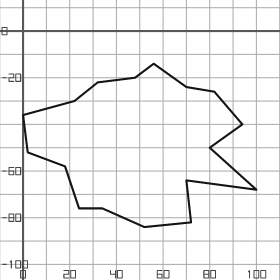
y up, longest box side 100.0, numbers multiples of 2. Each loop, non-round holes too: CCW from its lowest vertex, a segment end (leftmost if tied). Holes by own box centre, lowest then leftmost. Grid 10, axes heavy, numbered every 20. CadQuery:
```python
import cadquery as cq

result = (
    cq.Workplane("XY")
    .moveTo(52.0, -84.0)
    .lineTo(72.0, -82.0)
    .lineTo(70.0, -64.0)
    .lineTo(100.0, -68.0)
    .lineTo(80.0, -50.0)
    .lineTo(94.0, -40.0)
    .lineTo(82.0, -26.0)
    .lineTo(70.0, -24.0)
    .lineTo(56.0, -14.0)
    .lineTo(48.0, -20.0)
    .lineTo(32.0, -22.0)
    .lineTo(22.0, -30.0)
    .lineTo(0.0, -36.0)
    .lineTo(2.0, -52.0)
    .lineTo(18.0, -58.0)
    .lineTo(24.0, -76.0)
    .lineTo(34.0, -76.0)
    .close()
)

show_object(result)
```